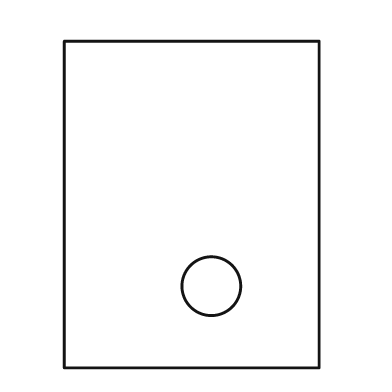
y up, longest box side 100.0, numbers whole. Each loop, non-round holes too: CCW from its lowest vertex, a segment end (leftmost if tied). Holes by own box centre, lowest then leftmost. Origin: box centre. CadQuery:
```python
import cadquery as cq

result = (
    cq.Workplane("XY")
    .moveTo(-39.0, -50.0)
    .lineTo(39.0, -50.0)
    .lineTo(39.0, 50.0)
    .lineTo(-39.0, 50.0)
    .close()
    .moveTo(6.0, -25.0)
    .circle(9.0)
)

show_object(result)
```